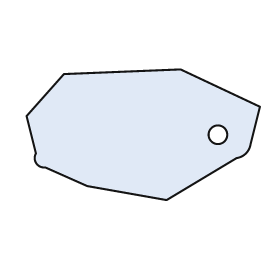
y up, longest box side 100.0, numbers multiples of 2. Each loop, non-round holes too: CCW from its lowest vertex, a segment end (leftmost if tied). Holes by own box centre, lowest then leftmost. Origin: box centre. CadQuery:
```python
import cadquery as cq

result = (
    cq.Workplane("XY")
    .moveTo(10.0, -28.0)
    .lineTo(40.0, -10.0)
    .threePointArc((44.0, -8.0), (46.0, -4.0))
    .lineTo(50.0, 12.0)
    .lineTo(16.0, 28.0)
    .lineTo(-34.0, 26.0)
    .lineTo(-50.0, 8.0)
    .lineTo(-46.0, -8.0)
    .threePointArc((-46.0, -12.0), (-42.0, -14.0))
    .lineTo(-24.0, -22.0)
    .close()
    .moveTo(32.0, 0.0)
    .circle(4.0)
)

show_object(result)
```